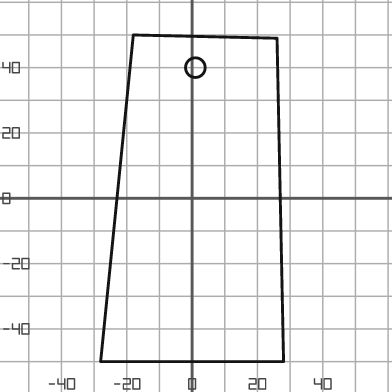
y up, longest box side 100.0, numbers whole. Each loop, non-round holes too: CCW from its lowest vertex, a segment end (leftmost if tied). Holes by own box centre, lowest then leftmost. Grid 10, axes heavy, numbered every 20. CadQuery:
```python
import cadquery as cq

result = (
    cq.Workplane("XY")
    .moveTo(-28.0, -50.0)
    .lineTo(28.0, -50.0)
    .lineTo(26.0, 49.0)
    .lineTo(-18.0, 50.0)
    .close()
    .moveTo(1.0, 40.0)
    .circle(3.0)
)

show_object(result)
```